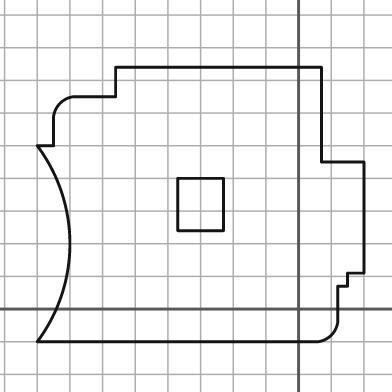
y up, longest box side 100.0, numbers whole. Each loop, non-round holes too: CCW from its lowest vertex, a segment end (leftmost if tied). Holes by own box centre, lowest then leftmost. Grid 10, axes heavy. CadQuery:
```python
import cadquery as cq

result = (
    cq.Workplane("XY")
    .moveTo(-80.0, -10.0)
    .lineTo(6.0, -10.0)
    .threePointArc((10.0, -8.0), (12.0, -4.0))
    .lineTo(12.0, 7.0)
    .lineTo(15.0, 7.0)
    .lineTo(15.0, 11.0)
    .lineTo(20.0, 11.0)
    .lineTo(20.0, 45.0)
    .lineTo(7.0, 45.0)
    .lineTo(7.0, 74.0)
    .lineTo(-56.0, 74.0)
    .lineTo(-56.0, 65.0)
    .lineTo(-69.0, 65.0)
    .threePointArc((-73.0, 63.0), (-75.0, 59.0))
    .lineTo(-75.0, 50.0)
    .lineTo(-80.0, 50.0)
    .threePointArc((-70.0, 20.0), (-80.0, -10.0))
    .close()
    .moveTo(-37.0, 24.0)
    .lineTo(-23.0, 24.0)
    .lineTo(-23.0, 40.0)
    .lineTo(-37.0, 40.0)
    .close()
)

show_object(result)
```